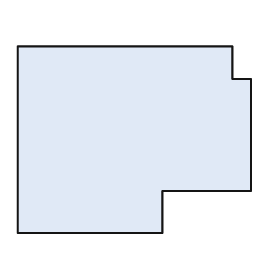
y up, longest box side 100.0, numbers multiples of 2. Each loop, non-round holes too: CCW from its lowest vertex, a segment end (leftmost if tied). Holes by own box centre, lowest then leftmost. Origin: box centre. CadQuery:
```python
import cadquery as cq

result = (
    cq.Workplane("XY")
    .moveTo(-50.0, -40.0)
    .lineTo(12.0, -40.0)
    .lineTo(12.0, -22.0)
    .lineTo(50.0, -22.0)
    .lineTo(50.0, 26.0)
    .lineTo(42.0, 26.0)
    .lineTo(42.0, 40.0)
    .lineTo(-50.0, 40.0)
    .close()
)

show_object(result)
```